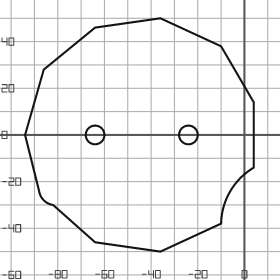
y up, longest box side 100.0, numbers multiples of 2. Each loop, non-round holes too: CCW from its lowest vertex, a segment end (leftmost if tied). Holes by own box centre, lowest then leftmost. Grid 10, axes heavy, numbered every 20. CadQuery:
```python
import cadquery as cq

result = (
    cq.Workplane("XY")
    .moveTo(-36.0, -50.0)
    .lineTo(-10.0, -38.0)
    .threePointArc((-6.0, -24.0), (4.0, -14.0))
    .lineTo(4.0, 14.0)
    .lineTo(-10.0, 38.0)
    .lineTo(-36.0, 50.0)
    .lineTo(-64.0, 46.0)
    .lineTo(-86.0, 28.0)
    .lineTo(-94.0, 0.0)
    .lineTo(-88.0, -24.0)
    .threePointArc((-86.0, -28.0), (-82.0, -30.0))
    .lineTo(-64.0, -46.0)
    .close()
    .moveTo(-64.0, 0.0)
    .circle(4.0)
    .moveTo(-24.0, 0.0)
    .circle(4.0)
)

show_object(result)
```